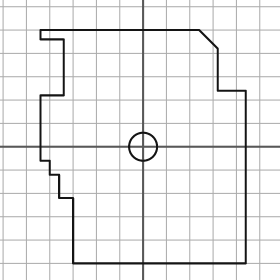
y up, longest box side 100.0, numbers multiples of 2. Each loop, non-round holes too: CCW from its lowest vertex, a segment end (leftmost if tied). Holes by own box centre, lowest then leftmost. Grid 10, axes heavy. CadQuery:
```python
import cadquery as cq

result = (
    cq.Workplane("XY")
    .moveTo(-30.0, -50.0)
    .lineTo(44.0, -50.0)
    .lineTo(44.0, 24.0)
    .lineTo(32.0, 24.0)
    .lineTo(32.0, 42.0)
    .lineTo(24.0, 50.0)
    .lineTo(-44.0, 50.0)
    .lineTo(-44.0, 46.0)
    .lineTo(-34.0, 46.0)
    .lineTo(-34.0, 22.0)
    .lineTo(-44.0, 22.0)
    .lineTo(-44.0, -6.0)
    .lineTo(-40.0, -6.0)
    .lineTo(-40.0, -12.0)
    .lineTo(-36.0, -12.0)
    .lineTo(-36.0, -22.0)
    .lineTo(-30.0, -22.0)
    .close()
    .moveTo(0.0, 0.0)
    .circle(6.0)
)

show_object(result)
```